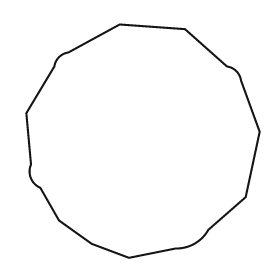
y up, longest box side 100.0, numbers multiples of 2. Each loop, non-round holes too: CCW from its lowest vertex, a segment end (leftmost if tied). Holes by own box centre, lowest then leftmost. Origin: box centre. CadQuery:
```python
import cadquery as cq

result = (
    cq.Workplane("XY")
    .moveTo(-6.0, -50.0)
    .lineTo(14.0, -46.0)
    .threePointArc((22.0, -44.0), (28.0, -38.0))
    .lineTo(44.0, -24.0)
    .lineTo(50.0, 4.0)
    .lineTo(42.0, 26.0)
    .threePointArc((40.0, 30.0), (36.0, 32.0))
    .lineTo(18.0, 48.0)
    .lineTo(-10.0, 50.0)
    .lineTo(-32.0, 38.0)
    .threePointArc((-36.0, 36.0), (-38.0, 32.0))
    .lineTo(-50.0, 12.0)
    .lineTo(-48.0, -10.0)
    .threePointArc((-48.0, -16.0), (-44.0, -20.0))
    .lineTo(-36.0, -34.0)
    .lineTo(-22.0, -44.0)
    .close()
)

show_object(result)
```